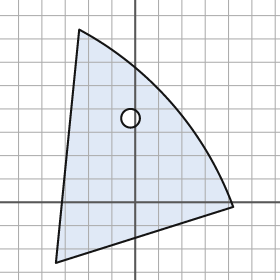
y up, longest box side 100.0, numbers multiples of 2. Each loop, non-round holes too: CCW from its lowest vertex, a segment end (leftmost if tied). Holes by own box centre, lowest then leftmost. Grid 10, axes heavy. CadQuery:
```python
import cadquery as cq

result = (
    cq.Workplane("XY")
    .moveTo(-34.0, -26.0)
    .lineTo(42.0, -2.0)
    .threePointArc((16.0, 42.0), (-24.0, 74.0))
    .close()
    .moveTo(-2.0, 36.0)
    .circle(4.0)
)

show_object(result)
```